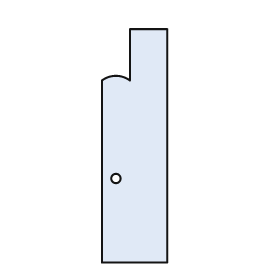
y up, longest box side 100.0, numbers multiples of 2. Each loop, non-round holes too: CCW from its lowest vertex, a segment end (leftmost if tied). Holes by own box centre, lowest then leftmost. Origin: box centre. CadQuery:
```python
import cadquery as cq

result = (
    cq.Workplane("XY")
    .moveTo(-14.0, -50.0)
    .lineTo(14.0, -50.0)
    .lineTo(14.0, 50.0)
    .lineTo(-2.0, 50.0)
    .lineTo(-2.0, 28.0)
    .threePointArc((-8.0, 30.0), (-14.0, 28.0))
    .close()
    .moveTo(-8.0, -14.0)
    .circle(2.0)
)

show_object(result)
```